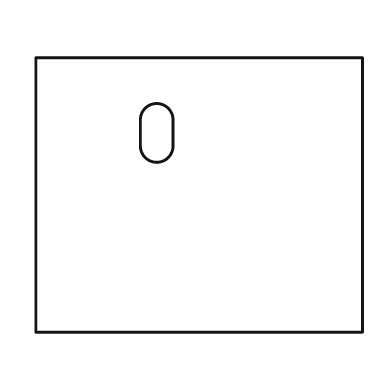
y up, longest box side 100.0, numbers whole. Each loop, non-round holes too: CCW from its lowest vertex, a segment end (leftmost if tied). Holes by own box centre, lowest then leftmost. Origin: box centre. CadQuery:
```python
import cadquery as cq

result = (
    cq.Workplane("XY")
    .moveTo(-50.0, -42.0)
    .lineTo(50.0, -42.0)
    .lineTo(50.0, 42.0)
    .lineTo(-50.0, 42.0)
    .close()
    .moveTo(-18.0, 15.0)
    .threePointArc((-13.0, 10.0), (-8.0, 15.0))
    .lineTo(-8.0, 23.0)
    .threePointArc((-13.0, 28.0), (-18.0, 23.0))
    .close()
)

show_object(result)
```